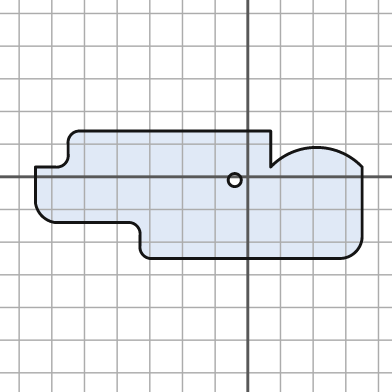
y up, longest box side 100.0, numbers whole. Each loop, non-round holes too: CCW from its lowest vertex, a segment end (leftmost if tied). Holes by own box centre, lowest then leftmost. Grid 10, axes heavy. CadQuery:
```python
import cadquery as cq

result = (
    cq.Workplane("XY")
    .moveTo(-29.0, -25.0)
    .lineTo(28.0, -25.0)
    .threePointArc((33.0, -23.0), (35.0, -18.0))
    .lineTo(35.0, 3.0)
    .threePointArc((21.0, 9.0), (7.0, 3.0))
    .lineTo(7.0, 14.0)
    .lineTo(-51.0, 14.0)
    .threePointArc((-54.0, 13.0), (-55.0, 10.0))
    .lineTo(-55.0, 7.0)
    .threePointArc((-56.0, 4.0), (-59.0, 3.0))
    .lineTo(-65.0, 3.0)
    .lineTo(-65.0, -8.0)
    .threePointArc((-63.0, -12.0), (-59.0, -14.0))
    .lineTo(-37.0, -14.0)
    .threePointArc((-34.0, -15.0), (-33.0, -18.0))
    .lineTo(-33.0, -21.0)
    .threePointArc((-32.0, -24.0), (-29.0, -25.0))
    .close()
    .moveTo(-4.0, -1.0)
    .circle(2.0)
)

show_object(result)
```